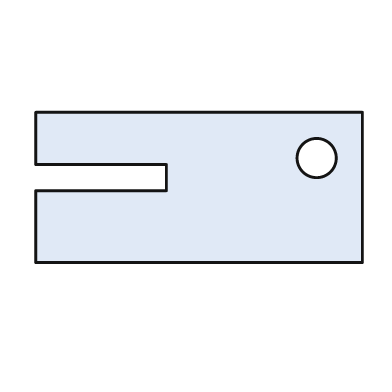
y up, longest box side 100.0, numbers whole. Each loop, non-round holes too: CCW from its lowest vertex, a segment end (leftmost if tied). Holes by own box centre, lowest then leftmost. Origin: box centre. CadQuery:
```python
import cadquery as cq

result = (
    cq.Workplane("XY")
    .moveTo(-50.0, -23.0)
    .lineTo(50.0, -23.0)
    .lineTo(50.0, 23.0)
    .lineTo(-50.0, 23.0)
    .lineTo(-50.0, 7.0)
    .lineTo(-10.0, 7.0)
    .lineTo(-10.0, -1.0)
    .lineTo(-50.0, -1.0)
    .close()
    .moveTo(36.0, 9.0)
    .circle(6.0)
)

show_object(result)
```